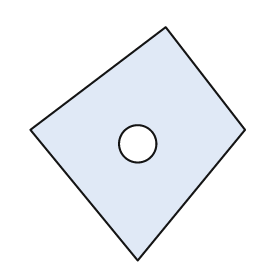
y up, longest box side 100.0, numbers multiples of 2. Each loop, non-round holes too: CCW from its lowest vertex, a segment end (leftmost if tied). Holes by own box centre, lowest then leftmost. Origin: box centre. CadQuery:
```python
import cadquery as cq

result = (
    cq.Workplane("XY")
    .moveTo(0.0, -50.0)
    .lineTo(46.0, 6.0)
    .lineTo(12.0, 50.0)
    .lineTo(-46.0, 6.0)
    .close()
    .moveTo(0.0, 0.0)
    .circle(8.0)
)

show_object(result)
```